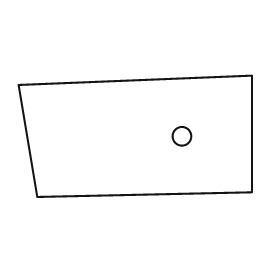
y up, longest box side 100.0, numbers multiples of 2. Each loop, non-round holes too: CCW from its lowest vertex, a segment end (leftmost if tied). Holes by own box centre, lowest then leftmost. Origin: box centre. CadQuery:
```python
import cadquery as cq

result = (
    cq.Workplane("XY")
    .moveTo(-42.0, -26.0)
    .lineTo(50.0, -24.0)
    .lineTo(50.0, 26.0)
    .lineTo(-50.0, 22.0)
    .close()
    .moveTo(20.0, 0.0)
    .circle(4.0)
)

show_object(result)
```